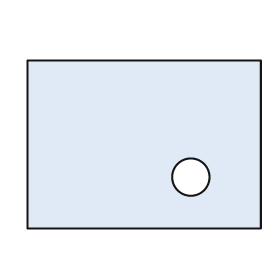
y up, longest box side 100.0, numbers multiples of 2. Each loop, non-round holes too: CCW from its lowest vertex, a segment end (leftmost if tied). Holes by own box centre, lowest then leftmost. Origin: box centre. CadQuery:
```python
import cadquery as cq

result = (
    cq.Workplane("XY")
    .moveTo(-50.0, -36.0)
    .lineTo(50.0, -36.0)
    .lineTo(50.0, 36.0)
    .lineTo(-50.0, 36.0)
    .close()
    .moveTo(20.0, -14.0)
    .circle(8.0)
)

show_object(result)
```